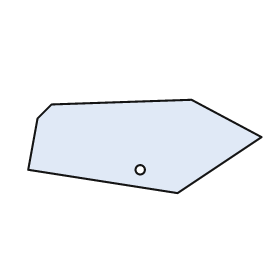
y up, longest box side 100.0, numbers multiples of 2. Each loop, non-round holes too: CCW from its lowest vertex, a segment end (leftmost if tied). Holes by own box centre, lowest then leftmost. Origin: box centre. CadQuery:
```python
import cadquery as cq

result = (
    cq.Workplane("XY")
    .moveTo(14.0, -20.0)
    .lineTo(50.0, 4.0)
    .lineTo(20.0, 20.0)
    .lineTo(-40.0, 18.0)
    .lineTo(-46.0, 12.0)
    .lineTo(-50.0, -10.0)
    .close()
    .moveTo(-2.0, -10.0)
    .circle(2.0)
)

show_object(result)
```